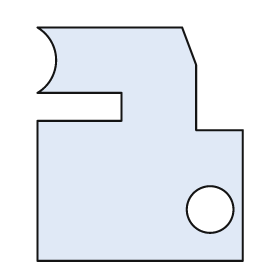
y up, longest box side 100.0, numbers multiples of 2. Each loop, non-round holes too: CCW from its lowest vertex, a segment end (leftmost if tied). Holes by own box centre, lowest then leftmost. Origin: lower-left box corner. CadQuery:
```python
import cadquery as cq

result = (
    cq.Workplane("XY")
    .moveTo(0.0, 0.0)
    .lineTo(88.0, 0.0)
    .lineTo(88.0, 56.0)
    .lineTo(68.0, 56.0)
    .lineTo(68.0, 84.0)
    .lineTo(62.0, 100.0)
    .lineTo(0.0, 100.0)
    .threePointArc((8.0, 86.0), (0.0, 72.0))
    .lineTo(36.0, 72.0)
    .lineTo(36.0, 60.0)
    .lineTo(0.0, 60.0)
    .close()
    .moveTo(74.0, 22.0)
    .circle(10.0)
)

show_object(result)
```